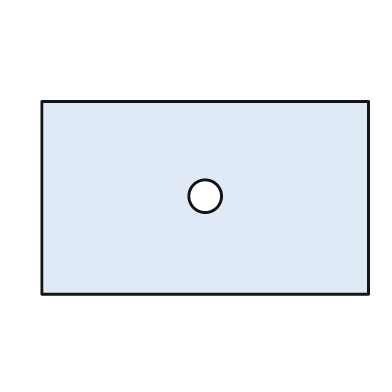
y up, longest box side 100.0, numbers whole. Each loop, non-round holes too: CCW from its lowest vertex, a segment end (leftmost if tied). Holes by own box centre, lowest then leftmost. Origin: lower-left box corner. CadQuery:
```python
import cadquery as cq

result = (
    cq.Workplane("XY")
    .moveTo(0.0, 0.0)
    .lineTo(100.0, 0.0)
    .lineTo(100.0, 59.0)
    .lineTo(0.0, 59.0)
    .close()
    .moveTo(50.0, 30.0)
    .circle(5.0)
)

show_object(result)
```